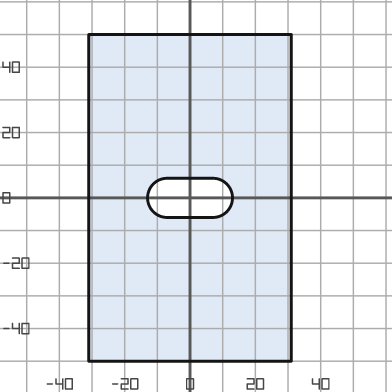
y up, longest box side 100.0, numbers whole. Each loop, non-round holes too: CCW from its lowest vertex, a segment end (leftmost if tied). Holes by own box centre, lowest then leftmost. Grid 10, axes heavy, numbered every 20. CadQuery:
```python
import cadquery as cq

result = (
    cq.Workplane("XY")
    .moveTo(-31.0, -50.0)
    .lineTo(31.0, -50.0)
    .lineTo(31.0, 50.0)
    .lineTo(-31.0, 50.0)
    .close()
    .moveTo(-7.0, -6.0)
    .lineTo(7.0, -6.0)
    .threePointArc((13.0, 0.0), (7.0, 6.0))
    .lineTo(-7.0, 6.0)
    .threePointArc((-13.0, 0.0), (-7.0, -6.0))
    .close()
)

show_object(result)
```